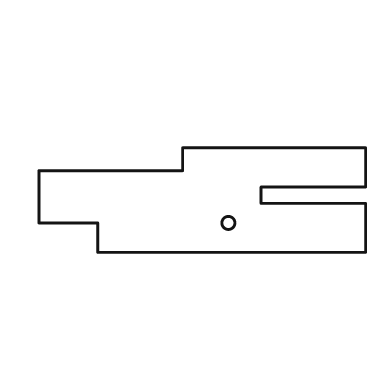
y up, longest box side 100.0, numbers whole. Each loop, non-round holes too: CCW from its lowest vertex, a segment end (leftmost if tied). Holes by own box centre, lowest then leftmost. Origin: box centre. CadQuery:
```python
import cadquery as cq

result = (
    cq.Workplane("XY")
    .moveTo(-32.0, -16.0)
    .lineTo(50.0, -16.0)
    .lineTo(50.0, -1.0)
    .lineTo(18.0, -1.0)
    .lineTo(18.0, 4.0)
    .lineTo(50.0, 4.0)
    .lineTo(50.0, 16.0)
    .lineTo(-6.0, 16.0)
    .lineTo(-6.0, 9.0)
    .lineTo(-50.0, 9.0)
    .lineTo(-50.0, -7.0)
    .lineTo(-32.0, -7.0)
    .close()
    .moveTo(8.0, -7.0)
    .circle(2.0)
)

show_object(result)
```